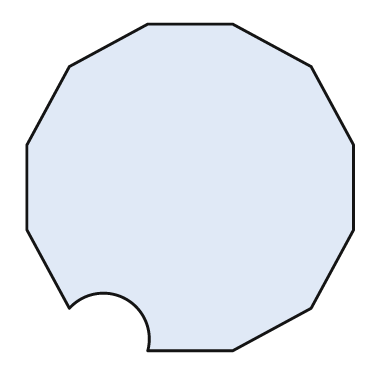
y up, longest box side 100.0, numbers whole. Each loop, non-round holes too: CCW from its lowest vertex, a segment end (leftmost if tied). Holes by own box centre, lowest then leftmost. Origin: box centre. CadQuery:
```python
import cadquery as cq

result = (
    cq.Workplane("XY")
    .moveTo(-13.0, -50.0)
    .lineTo(13.0, -50.0)
    .lineTo(37.0, -37.0)
    .lineTo(50.0, -13.0)
    .lineTo(50.0, 13.0)
    .lineTo(37.0, 37.0)
    .lineTo(13.0, 50.0)
    .lineTo(-13.0, 50.0)
    .lineTo(-37.0, 37.0)
    .lineTo(-50.0, 13.0)
    .lineTo(-50.0, -13.0)
    .lineTo(-37.0, -37.0)
    .threePointArc((-20.0, -34.0), (-13.0, -50.0))
    .close()
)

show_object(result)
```